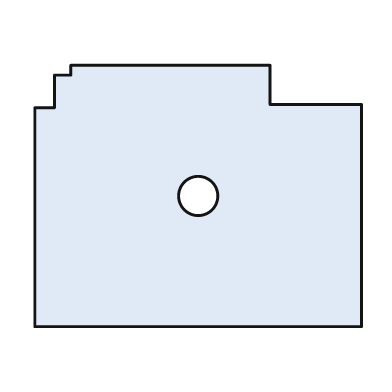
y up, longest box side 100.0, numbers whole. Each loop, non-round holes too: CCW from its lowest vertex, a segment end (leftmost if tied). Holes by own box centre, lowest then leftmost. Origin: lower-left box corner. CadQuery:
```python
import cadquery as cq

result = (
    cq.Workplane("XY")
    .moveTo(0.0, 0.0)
    .lineTo(100.0, 0.0)
    .lineTo(100.0, 68.0)
    .lineTo(72.0, 68.0)
    .lineTo(72.0, 80.0)
    .lineTo(11.0, 80.0)
    .lineTo(11.0, 77.0)
    .lineTo(6.0, 77.0)
    .lineTo(6.0, 67.0)
    .lineTo(0.0, 67.0)
    .close()
    .moveTo(50.0, 40.0)
    .circle(6.0)
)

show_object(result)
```